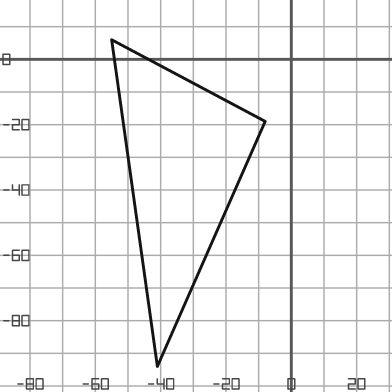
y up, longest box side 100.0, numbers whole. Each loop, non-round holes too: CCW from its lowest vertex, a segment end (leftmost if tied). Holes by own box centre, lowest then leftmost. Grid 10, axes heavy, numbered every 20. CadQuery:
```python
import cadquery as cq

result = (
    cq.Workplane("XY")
    .moveTo(-41.0, -94.0)
    .lineTo(-8.0, -19.0)
    .lineTo(-55.0, 6.0)
    .close()
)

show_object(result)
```